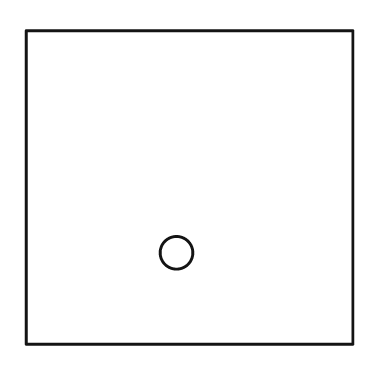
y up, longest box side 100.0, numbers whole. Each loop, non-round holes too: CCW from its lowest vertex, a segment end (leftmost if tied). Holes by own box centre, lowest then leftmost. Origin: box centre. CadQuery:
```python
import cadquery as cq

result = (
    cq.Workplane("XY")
    .moveTo(-50.0, -48.0)
    .lineTo(50.0, -48.0)
    .lineTo(50.0, 48.0)
    .lineTo(-50.0, 48.0)
    .close()
    .moveTo(-4.0, -20.0)
    .circle(5.0)
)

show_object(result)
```